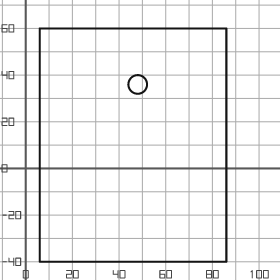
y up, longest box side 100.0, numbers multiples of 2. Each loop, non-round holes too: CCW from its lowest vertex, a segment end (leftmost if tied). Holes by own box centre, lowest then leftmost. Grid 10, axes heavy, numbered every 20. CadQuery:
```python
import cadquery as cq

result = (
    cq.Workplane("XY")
    .moveTo(6.0, -40.0)
    .lineTo(86.0, -40.0)
    .lineTo(86.0, 60.0)
    .lineTo(6.0, 60.0)
    .close()
    .moveTo(48.0, 36.0)
    .circle(4.0)
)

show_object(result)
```